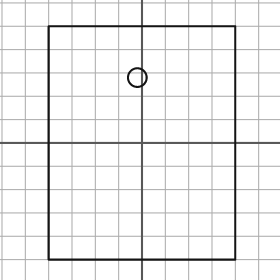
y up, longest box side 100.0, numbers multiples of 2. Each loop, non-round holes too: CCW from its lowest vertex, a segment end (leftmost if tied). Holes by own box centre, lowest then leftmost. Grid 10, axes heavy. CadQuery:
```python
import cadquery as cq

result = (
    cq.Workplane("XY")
    .moveTo(-40.0, -50.0)
    .lineTo(40.0, -50.0)
    .lineTo(40.0, 50.0)
    .lineTo(-40.0, 50.0)
    .close()
    .moveTo(-2.0, 28.0)
    .circle(4.0)
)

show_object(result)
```